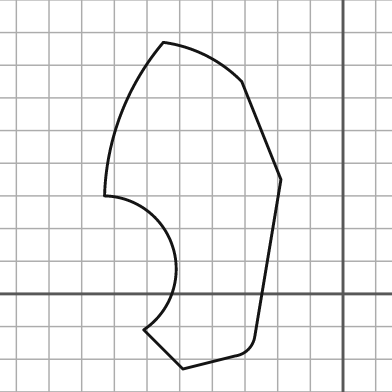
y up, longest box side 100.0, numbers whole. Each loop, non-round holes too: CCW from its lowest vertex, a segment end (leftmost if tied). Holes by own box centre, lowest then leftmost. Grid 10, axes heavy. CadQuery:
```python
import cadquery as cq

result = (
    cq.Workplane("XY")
    .moveTo(-49.0, -23.0)
    .lineTo(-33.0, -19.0)
    .threePointArc((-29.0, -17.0), (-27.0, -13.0))
    .lineTo(-19.0, 35.0)
    .lineTo(-31.0, 65.0)
    .threePointArc((-42.0, 73.0), (-55.0, 77.0))
    .threePointArc((-68.0, 55.0), (-73.0, 30.0))
    .threePointArc((-52.0, 14.0), (-61.0, -11.0))
    .close()
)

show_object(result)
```